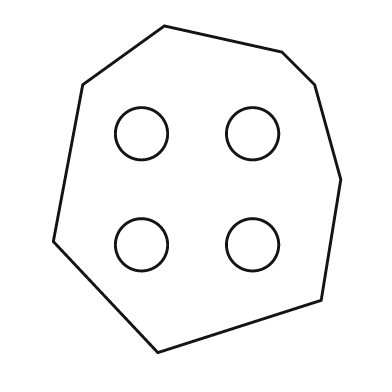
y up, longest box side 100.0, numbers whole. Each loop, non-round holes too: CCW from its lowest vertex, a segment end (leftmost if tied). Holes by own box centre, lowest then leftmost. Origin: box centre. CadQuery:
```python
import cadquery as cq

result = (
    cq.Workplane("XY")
    .moveTo(-12.0, -50.0)
    .lineTo(38.0, -34.0)
    .lineTo(44.0, 3.0)
    .lineTo(36.0, 32.0)
    .lineTo(26.0, 42.0)
    .lineTo(-10.0, 50.0)
    .lineTo(-35.0, 32.0)
    .lineTo(-44.0, -16.0)
    .close()
    .moveTo(-17.0, -17.0)
    .circle(8.0)
    .moveTo(17.0, -17.0)
    .circle(8.0)
    .moveTo(-17.0, 17.0)
    .circle(8.0)
    .moveTo(17.0, 17.0)
    .circle(8.0)
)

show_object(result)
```